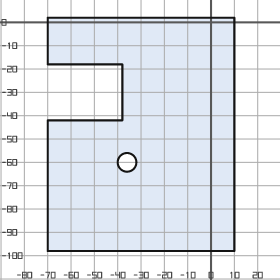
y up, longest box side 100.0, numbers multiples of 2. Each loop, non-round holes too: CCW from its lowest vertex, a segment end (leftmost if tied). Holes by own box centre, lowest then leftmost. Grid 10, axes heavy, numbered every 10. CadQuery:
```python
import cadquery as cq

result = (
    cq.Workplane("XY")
    .moveTo(-70.0, -98.0)
    .lineTo(10.0, -98.0)
    .lineTo(10.0, 2.0)
    .lineTo(-70.0, 2.0)
    .lineTo(-70.0, -18.0)
    .lineTo(-38.0, -18.0)
    .lineTo(-38.0, -42.0)
    .lineTo(-70.0, -42.0)
    .close()
    .moveTo(-36.0, -60.0)
    .circle(4.0)
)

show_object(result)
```